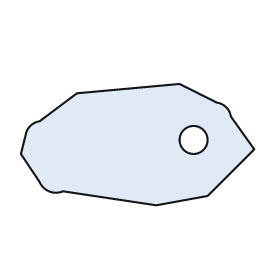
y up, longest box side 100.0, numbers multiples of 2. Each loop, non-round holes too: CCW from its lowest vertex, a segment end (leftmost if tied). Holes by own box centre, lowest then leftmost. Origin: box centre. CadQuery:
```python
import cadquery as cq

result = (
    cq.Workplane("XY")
    .moveTo(8.0, -26.0)
    .lineTo(30.0, -22.0)
    .lineTo(50.0, -2.0)
    .lineTo(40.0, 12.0)
    .threePointArc((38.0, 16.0), (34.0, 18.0))
    .lineTo(18.0, 26.0)
    .lineTo(-26.0, 22.0)
    .lineTo(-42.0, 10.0)
    .threePointArc((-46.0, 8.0), (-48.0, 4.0))
    .lineTo(-50.0, -4.0)
    .lineTo(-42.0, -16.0)
    .threePointArc((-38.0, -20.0), (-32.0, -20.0))
    .close()
    .moveTo(24.0, 2.0)
    .circle(6.0)
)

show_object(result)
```